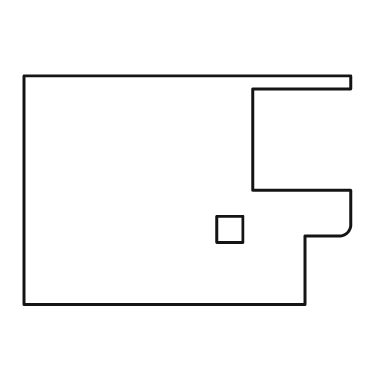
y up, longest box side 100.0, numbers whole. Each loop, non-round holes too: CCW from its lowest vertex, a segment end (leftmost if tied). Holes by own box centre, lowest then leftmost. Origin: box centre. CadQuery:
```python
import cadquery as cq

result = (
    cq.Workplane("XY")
    .moveTo(-50.0, -35.0)
    .lineTo(36.0, -35.0)
    .lineTo(36.0, -14.0)
    .lineTo(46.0, -14.0)
    .threePointArc((49.0, -13.0), (50.0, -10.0))
    .lineTo(50.0, 0.0)
    .lineTo(20.0, 0.0)
    .lineTo(20.0, 31.0)
    .lineTo(50.0, 31.0)
    .lineTo(50.0, 35.0)
    .lineTo(-50.0, 35.0)
    .close()
    .moveTo(9.0, -16.0)
    .lineTo(17.0, -16.0)
    .lineTo(17.0, -8.0)
    .lineTo(9.0, -8.0)
    .close()
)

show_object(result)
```